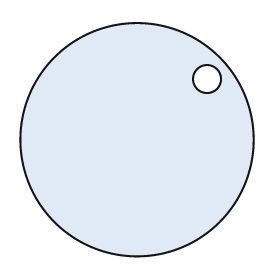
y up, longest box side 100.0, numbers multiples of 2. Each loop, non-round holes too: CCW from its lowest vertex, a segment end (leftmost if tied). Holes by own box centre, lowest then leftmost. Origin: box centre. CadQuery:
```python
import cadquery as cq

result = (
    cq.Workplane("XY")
    .moveTo(0.0, 0.0)
    .circle(50.0)
    .moveTo(30.0, 26.0)
    .circle(6.0)
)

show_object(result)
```